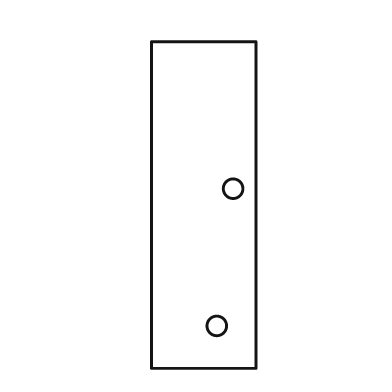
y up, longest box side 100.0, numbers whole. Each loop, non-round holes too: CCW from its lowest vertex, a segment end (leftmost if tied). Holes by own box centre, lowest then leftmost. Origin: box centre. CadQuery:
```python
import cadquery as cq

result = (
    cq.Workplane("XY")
    .moveTo(-16.0, -50.0)
    .lineTo(16.0, -50.0)
    .lineTo(16.0, 50.0)
    .lineTo(-16.0, 50.0)
    .close()
    .moveTo(4.0, -37.0)
    .circle(3.0)
    .moveTo(9.0, 5.0)
    .circle(3.0)
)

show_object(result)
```